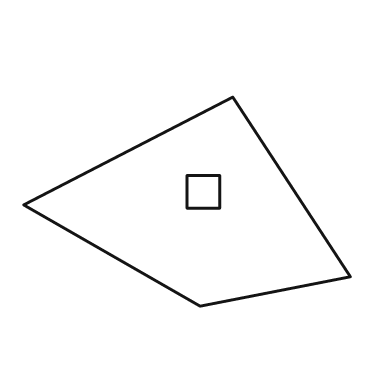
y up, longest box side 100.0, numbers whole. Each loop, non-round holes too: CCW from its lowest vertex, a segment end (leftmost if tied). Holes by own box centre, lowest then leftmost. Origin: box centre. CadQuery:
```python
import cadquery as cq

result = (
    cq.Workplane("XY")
    .moveTo(4.0, -32.0)
    .lineTo(50.0, -23.0)
    .lineTo(14.0, 32.0)
    .lineTo(-50.0, -1.0)
    .close()
    .moveTo(0.0, -2.0)
    .lineTo(10.0, -2.0)
    .lineTo(10.0, 8.0)
    .lineTo(0.0, 8.0)
    .close()
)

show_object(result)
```